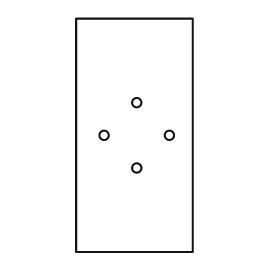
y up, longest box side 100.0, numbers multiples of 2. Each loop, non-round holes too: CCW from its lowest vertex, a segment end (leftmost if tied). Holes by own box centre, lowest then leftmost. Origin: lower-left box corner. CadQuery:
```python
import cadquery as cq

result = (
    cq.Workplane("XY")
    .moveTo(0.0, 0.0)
    .lineTo(50.0, 0.0)
    .lineTo(50.0, 100.0)
    .lineTo(0.0, 100.0)
    .close()
    .moveTo(26.0, 36.0)
    .circle(2.0)
    .moveTo(12.0, 50.0)
    .circle(2.0)
    .moveTo(40.0, 50.0)
    .circle(2.0)
    .moveTo(26.0, 64.0)
    .circle(2.0)
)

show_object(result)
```